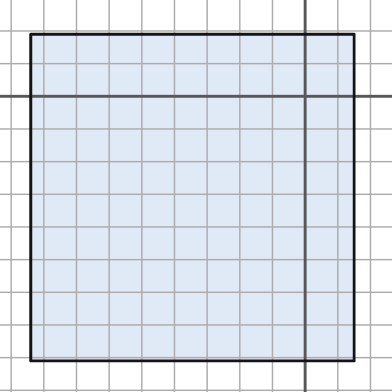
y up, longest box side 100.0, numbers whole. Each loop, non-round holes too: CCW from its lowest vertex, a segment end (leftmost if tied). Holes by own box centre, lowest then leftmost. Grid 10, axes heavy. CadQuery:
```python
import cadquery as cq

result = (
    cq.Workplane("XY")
    .moveTo(-84.0, -81.0)
    .lineTo(15.0, -81.0)
    .lineTo(15.0, 19.0)
    .lineTo(-84.0, 19.0)
    .close()
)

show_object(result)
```